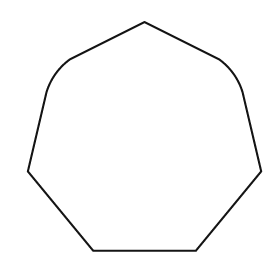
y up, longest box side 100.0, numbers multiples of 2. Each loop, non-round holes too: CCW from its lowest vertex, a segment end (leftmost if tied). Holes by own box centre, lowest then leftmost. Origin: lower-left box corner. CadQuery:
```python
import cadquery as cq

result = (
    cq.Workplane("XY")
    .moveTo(28.0, 0.0)
    .lineTo(72.0, 0.0)
    .lineTo(100.0, 34.0)
    .lineTo(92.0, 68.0)
    .threePointArc((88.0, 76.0), (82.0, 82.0))
    .lineTo(50.0, 98.0)
    .lineTo(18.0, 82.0)
    .threePointArc((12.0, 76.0), (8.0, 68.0))
    .lineTo(0.0, 34.0)
    .close()
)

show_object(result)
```